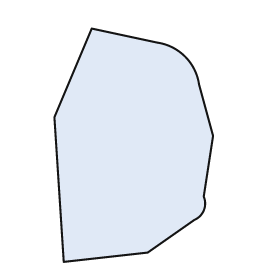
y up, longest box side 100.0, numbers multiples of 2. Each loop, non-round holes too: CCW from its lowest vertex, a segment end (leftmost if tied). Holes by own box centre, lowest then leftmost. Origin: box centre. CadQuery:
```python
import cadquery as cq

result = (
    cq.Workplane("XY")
    .moveTo(-30.0, -50.0)
    .lineTo(6.0, -46.0)
    .lineTo(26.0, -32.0)
    .threePointArc((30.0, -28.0), (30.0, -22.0))
    .lineTo(34.0, 4.0)
    .lineTo(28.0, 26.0)
    .threePointArc((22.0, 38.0), (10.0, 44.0))
    .lineTo(-18.0, 50.0)
    .lineTo(-34.0, 12.0)
    .close()
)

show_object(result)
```